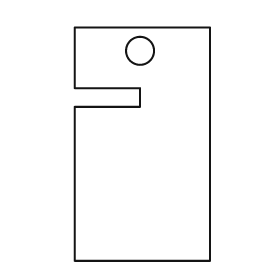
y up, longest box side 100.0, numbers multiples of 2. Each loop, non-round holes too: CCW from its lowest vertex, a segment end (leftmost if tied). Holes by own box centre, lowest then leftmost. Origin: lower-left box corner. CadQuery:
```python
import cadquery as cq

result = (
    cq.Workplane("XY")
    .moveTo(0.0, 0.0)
    .lineTo(58.0, 0.0)
    .lineTo(58.0, 100.0)
    .lineTo(0.0, 100.0)
    .lineTo(0.0, 74.0)
    .lineTo(28.0, 74.0)
    .lineTo(28.0, 66.0)
    .lineTo(0.0, 66.0)
    .close()
    .moveTo(28.0, 90.0)
    .circle(6.0)
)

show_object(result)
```